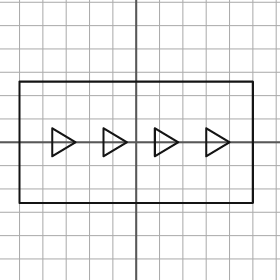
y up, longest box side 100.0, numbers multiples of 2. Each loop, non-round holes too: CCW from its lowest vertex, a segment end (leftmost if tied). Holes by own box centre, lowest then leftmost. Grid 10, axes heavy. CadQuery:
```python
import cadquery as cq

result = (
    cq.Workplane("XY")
    .moveTo(-50.0, -26.0)
    .lineTo(50.0, -26.0)
    .lineTo(50.0, 26.0)
    .lineTo(-50.0, 26.0)
    .close()
    .moveTo(-36.0, -6.0)
    .lineTo(-26.0, 0.0)
    .lineTo(-36.0, 6.0)
    .close()
    .moveTo(-14.0, -6.0)
    .lineTo(-4.0, 0.0)
    .lineTo(-14.0, 6.0)
    .close()
    .moveTo(8.0, -6.0)
    .lineTo(18.0, 0.0)
    .lineTo(8.0, 6.0)
    .close()
    .moveTo(30.0, -6.0)
    .lineTo(40.0, 0.0)
    .lineTo(30.0, 6.0)
    .close()
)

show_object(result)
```